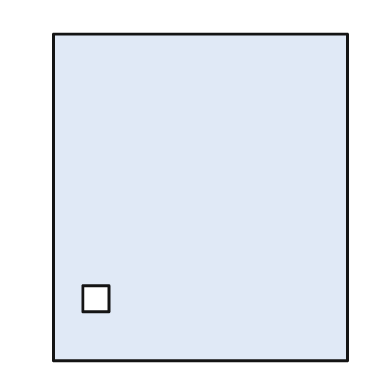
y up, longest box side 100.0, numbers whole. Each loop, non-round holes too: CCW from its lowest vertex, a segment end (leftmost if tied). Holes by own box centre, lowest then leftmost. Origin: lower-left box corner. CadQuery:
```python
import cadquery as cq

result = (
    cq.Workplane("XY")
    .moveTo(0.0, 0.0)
    .lineTo(90.0, 0.0)
    .lineTo(90.0, 100.0)
    .lineTo(0.0, 100.0)
    .close()
    .moveTo(9.0, 15.0)
    .lineTo(17.0, 15.0)
    .lineTo(17.0, 23.0)
    .lineTo(9.0, 23.0)
    .close()
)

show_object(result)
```